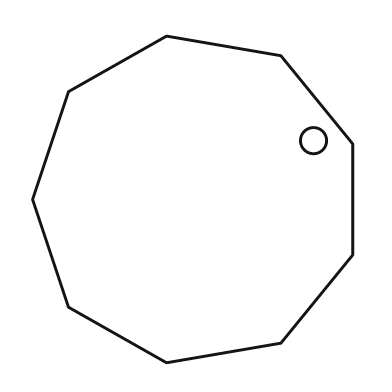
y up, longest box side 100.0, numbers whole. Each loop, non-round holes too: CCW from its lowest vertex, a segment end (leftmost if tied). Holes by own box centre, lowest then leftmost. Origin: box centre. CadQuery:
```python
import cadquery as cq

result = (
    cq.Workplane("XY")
    .moveTo(-8.0, -50.0)
    .lineTo(27.0, -44.0)
    .lineTo(49.0, -17.0)
    .lineTo(49.0, 17.0)
    .lineTo(27.0, 44.0)
    .lineTo(-8.0, 50.0)
    .lineTo(-38.0, 33.0)
    .lineTo(-49.0, 0.0)
    .lineTo(-38.0, -33.0)
    .close()
    .moveTo(37.0, 18.0)
    .circle(4.0)
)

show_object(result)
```